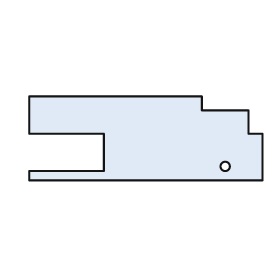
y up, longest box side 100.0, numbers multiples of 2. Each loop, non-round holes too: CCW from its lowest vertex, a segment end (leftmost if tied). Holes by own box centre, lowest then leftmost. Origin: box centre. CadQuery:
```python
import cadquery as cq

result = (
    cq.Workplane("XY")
    .moveTo(-50.0, -18.0)
    .lineTo(50.0, -18.0)
    .lineTo(50.0, 2.0)
    .lineTo(44.0, 2.0)
    .lineTo(44.0, 12.0)
    .lineTo(24.0, 12.0)
    .lineTo(24.0, 18.0)
    .lineTo(-50.0, 18.0)
    .lineTo(-50.0, 2.0)
    .lineTo(-18.0, 2.0)
    .lineTo(-18.0, -14.0)
    .lineTo(-50.0, -14.0)
    .close()
    .moveTo(34.0, -12.0)
    .circle(2.0)
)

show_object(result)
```